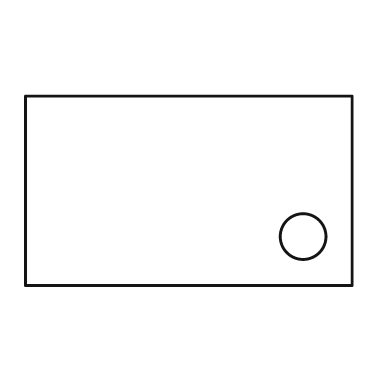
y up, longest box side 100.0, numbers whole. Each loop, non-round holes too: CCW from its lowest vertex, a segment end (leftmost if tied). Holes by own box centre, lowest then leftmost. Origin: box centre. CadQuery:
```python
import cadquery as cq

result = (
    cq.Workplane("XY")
    .moveTo(-50.0, -29.0)
    .lineTo(50.0, -29.0)
    .lineTo(50.0, 29.0)
    .lineTo(-50.0, 29.0)
    .close()
    .moveTo(35.0, -14.0)
    .circle(7.0)
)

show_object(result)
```